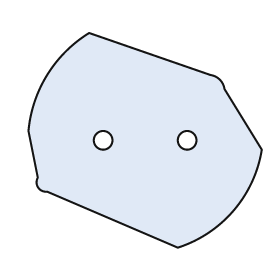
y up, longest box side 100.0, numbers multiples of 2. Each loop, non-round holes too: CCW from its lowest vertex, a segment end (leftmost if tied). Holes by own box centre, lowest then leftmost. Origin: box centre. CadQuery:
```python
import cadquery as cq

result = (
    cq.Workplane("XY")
    .moveTo(14.0, -46.0)
    .threePointArc((38.0, -30.0), (50.0, -4.0))
    .lineTo(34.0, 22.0)
    .threePointArc((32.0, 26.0), (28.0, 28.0))
    .lineTo(-24.0, 46.0)
    .threePointArc((-42.0, 28.0), (-50.0, 4.0))
    .lineTo(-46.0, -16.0)
    .threePointArc((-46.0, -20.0), (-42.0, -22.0))
    .close()
    .moveTo(-18.0, 0.0)
    .circle(4.0)
    .moveTo(18.0, 0.0)
    .circle(4.0)
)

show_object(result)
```